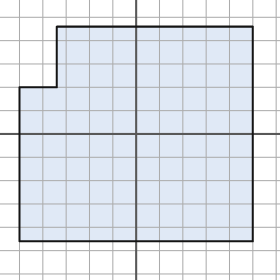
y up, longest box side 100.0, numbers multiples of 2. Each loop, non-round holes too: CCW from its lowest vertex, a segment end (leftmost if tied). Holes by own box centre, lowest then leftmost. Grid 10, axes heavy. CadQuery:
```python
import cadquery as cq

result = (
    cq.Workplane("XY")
    .moveTo(-50.0, -46.0)
    .lineTo(50.0, -46.0)
    .lineTo(50.0, 46.0)
    .lineTo(-34.0, 46.0)
    .lineTo(-34.0, 20.0)
    .lineTo(-50.0, 20.0)
    .close()
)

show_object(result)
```